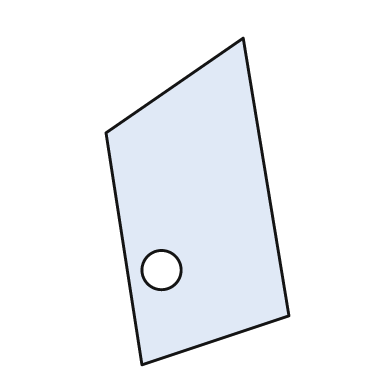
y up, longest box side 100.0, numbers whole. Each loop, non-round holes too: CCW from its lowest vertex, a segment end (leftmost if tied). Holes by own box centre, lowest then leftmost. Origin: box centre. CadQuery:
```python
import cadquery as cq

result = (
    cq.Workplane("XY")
    .moveTo(-17.0, -50.0)
    .lineTo(28.0, -35.0)
    .lineTo(14.0, 50.0)
    .lineTo(-28.0, 21.0)
    .close()
    .moveTo(-11.0, -21.0)
    .circle(6.0)
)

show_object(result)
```